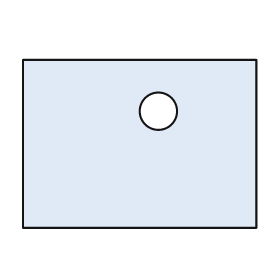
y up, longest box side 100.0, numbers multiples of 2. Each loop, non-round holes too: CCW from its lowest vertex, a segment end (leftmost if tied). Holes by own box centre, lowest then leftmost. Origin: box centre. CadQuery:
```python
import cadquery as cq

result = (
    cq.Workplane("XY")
    .moveTo(-50.0, -36.0)
    .lineTo(50.0, -36.0)
    .lineTo(50.0, 36.0)
    .lineTo(-50.0, 36.0)
    .close()
    .moveTo(8.0, 14.0)
    .circle(8.0)
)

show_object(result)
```